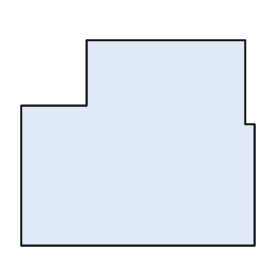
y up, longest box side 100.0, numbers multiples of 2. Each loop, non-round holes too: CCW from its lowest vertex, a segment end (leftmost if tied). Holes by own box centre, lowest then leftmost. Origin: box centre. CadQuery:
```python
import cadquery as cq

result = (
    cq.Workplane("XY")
    .moveTo(-50.0, -44.0)
    .lineTo(50.0, -44.0)
    .lineTo(50.0, 8.0)
    .lineTo(46.0, 8.0)
    .lineTo(46.0, 44.0)
    .lineTo(-22.0, 44.0)
    .lineTo(-22.0, 16.0)
    .lineTo(-50.0, 16.0)
    .close()
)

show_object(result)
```